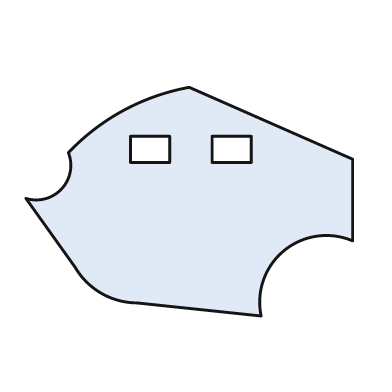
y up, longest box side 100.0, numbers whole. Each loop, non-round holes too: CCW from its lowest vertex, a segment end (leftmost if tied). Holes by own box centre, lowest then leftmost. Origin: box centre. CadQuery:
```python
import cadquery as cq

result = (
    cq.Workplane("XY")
    .moveTo(22.0, -35.0)
    .threePointArc((29.0, -15.0), (50.0, -12.0))
    .lineTo(50.0, 13.0)
    .lineTo(0.0, 35.0)
    .threePointArc((-20.0, 28.0), (-37.0, 15.0))
    .threePointArc((-39.0, 4.0), (-50.0, 1.0))
    .lineTo(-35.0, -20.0)
    .threePointArc((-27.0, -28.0), (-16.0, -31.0))
    .close()
    .moveTo(-18.0, 12.0)
    .lineTo(-6.0, 12.0)
    .lineTo(-6.0, 20.0)
    .lineTo(-18.0, 20.0)
    .close()
    .moveTo(7.0, 12.0)
    .lineTo(19.0, 12.0)
    .lineTo(19.0, 20.0)
    .lineTo(7.0, 20.0)
    .close()
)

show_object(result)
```